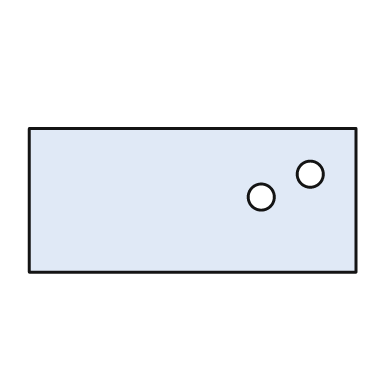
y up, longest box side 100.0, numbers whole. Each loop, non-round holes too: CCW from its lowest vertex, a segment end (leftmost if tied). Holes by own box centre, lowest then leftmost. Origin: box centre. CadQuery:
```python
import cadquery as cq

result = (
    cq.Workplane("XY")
    .moveTo(-50.0, -22.0)
    .lineTo(50.0, -22.0)
    .lineTo(50.0, 22.0)
    .lineTo(-50.0, 22.0)
    .close()
    .moveTo(21.0, 1.0)
    .circle(4.0)
    .moveTo(36.0, 8.0)
    .circle(4.0)
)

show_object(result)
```